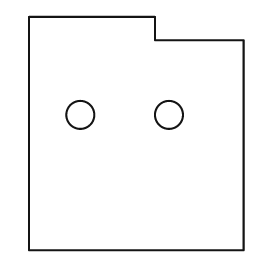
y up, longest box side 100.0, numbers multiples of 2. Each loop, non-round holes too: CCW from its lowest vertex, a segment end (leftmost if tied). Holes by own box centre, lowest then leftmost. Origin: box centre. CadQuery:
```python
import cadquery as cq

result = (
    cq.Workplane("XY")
    .moveTo(-46.0, -50.0)
    .lineTo(46.0, -50.0)
    .lineTo(46.0, 40.0)
    .lineTo(8.0, 40.0)
    .lineTo(8.0, 50.0)
    .lineTo(-46.0, 50.0)
    .close()
    .moveTo(-24.0, 8.0)
    .circle(6.0)
    .moveTo(14.0, 8.0)
    .circle(6.0)
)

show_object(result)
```